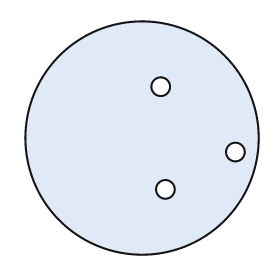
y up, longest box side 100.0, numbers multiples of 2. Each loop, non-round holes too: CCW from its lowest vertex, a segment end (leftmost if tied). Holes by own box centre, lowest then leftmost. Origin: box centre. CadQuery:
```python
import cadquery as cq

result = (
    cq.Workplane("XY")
    .moveTo(0.0, 0.0)
    .circle(50.0)
    .moveTo(10.0, -22.0)
    .circle(4.0)
    .moveTo(40.0, -6.0)
    .circle(4.0)
    .moveTo(8.0, 22.0)
    .circle(4.0)
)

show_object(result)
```